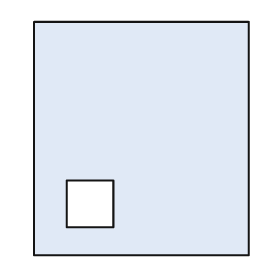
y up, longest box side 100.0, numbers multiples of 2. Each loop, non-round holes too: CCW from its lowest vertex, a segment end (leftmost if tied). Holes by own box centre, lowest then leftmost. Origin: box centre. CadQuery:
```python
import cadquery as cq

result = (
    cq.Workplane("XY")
    .moveTo(-46.0, -50.0)
    .lineTo(46.0, -50.0)
    .lineTo(46.0, 50.0)
    .lineTo(-46.0, 50.0)
    .close()
    .moveTo(-32.0, -38.0)
    .lineTo(-12.0, -38.0)
    .lineTo(-12.0, -18.0)
    .lineTo(-32.0, -18.0)
    .close()
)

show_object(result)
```